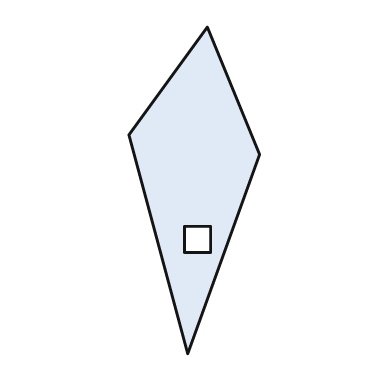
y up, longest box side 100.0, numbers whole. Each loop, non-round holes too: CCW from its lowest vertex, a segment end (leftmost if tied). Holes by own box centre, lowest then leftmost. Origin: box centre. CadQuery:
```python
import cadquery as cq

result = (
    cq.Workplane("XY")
    .moveTo(-2.0, -50.0)
    .lineTo(20.0, 11.0)
    .lineTo(4.0, 50.0)
    .lineTo(-20.0, 17.0)
    .close()
    .moveTo(-3.0, -19.0)
    .lineTo(5.0, -19.0)
    .lineTo(5.0, -11.0)
    .lineTo(-3.0, -11.0)
    .close()
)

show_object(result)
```